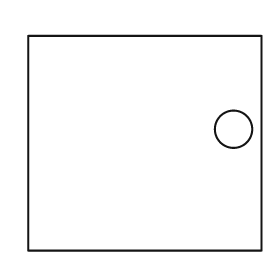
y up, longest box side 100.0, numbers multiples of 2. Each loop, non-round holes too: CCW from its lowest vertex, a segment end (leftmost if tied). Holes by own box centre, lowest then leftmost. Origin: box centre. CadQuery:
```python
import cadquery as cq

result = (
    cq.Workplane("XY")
    .moveTo(-50.0, -46.0)
    .lineTo(50.0, -46.0)
    .lineTo(50.0, 46.0)
    .lineTo(-50.0, 46.0)
    .close()
    .moveTo(38.0, 6.0)
    .circle(8.0)
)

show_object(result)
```